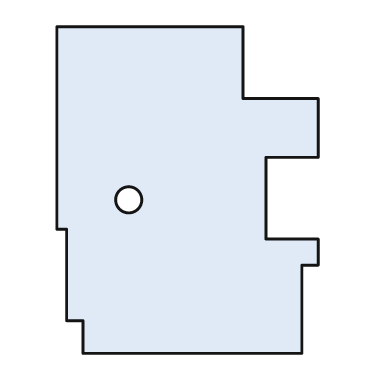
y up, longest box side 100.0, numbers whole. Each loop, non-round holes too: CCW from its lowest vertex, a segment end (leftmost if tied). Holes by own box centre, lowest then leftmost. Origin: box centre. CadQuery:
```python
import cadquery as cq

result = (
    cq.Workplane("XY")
    .moveTo(-32.0, -50.0)
    .lineTo(35.0, -50.0)
    .lineTo(35.0, -23.0)
    .lineTo(40.0, -23.0)
    .lineTo(40.0, -15.0)
    .lineTo(24.0, -15.0)
    .lineTo(24.0, 10.0)
    .lineTo(40.0, 10.0)
    .lineTo(40.0, 28.0)
    .lineTo(17.0, 28.0)
    .lineTo(17.0, 50.0)
    .lineTo(-40.0, 50.0)
    .lineTo(-40.0, -12.0)
    .lineTo(-37.0, -12.0)
    .lineTo(-37.0, -40.0)
    .lineTo(-32.0, -40.0)
    .close()
    .moveTo(-18.0, -3.0)
    .circle(4.0)
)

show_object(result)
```